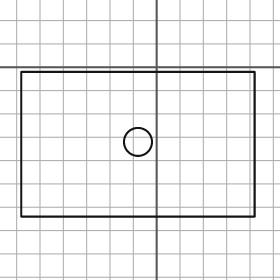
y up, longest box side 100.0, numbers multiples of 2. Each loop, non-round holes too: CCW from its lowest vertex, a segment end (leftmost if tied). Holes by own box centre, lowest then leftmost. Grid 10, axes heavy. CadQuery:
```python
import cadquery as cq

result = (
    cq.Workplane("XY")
    .moveTo(-58.0, -64.0)
    .lineTo(42.0, -64.0)
    .lineTo(42.0, -2.0)
    .lineTo(-58.0, -2.0)
    .close()
    .moveTo(-8.0, -32.0)
    .circle(6.0)
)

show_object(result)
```